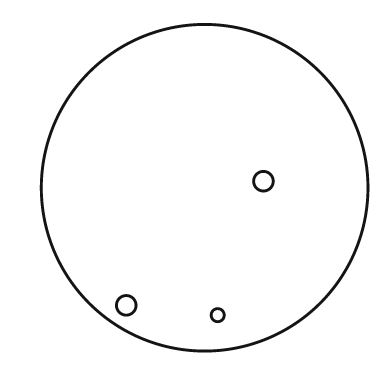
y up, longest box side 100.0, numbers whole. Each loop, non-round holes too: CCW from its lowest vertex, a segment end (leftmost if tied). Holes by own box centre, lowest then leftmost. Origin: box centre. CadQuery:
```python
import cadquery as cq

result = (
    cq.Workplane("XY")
    .moveTo(0.0, 0.0)
    .circle(50.0)
    .moveTo(4.0, -39.0)
    .circle(2.0)
    .moveTo(-24.0, -36.0)
    .circle(3.0)
    .moveTo(18.0, 2.0)
    .circle(3.0)
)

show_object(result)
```